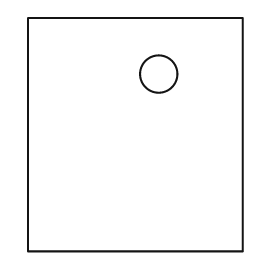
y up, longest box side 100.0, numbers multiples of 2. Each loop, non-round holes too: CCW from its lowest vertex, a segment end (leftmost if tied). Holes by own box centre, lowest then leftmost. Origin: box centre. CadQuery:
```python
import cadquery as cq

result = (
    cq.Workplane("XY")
    .moveTo(-46.0, -50.0)
    .lineTo(46.0, -50.0)
    .lineTo(46.0, 50.0)
    .lineTo(-46.0, 50.0)
    .close()
    .moveTo(10.0, 26.0)
    .circle(8.0)
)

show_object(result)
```